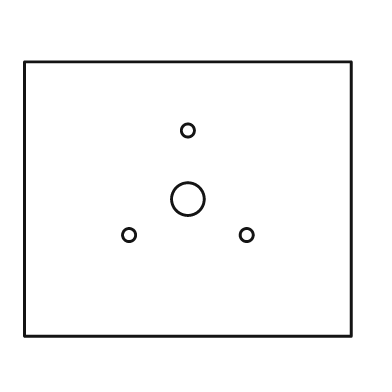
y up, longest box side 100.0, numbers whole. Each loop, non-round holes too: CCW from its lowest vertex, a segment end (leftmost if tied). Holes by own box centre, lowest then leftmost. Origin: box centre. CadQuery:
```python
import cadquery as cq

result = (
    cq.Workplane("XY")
    .moveTo(-50.0, -42.0)
    .lineTo(50.0, -42.0)
    .lineTo(50.0, 42.0)
    .lineTo(-50.0, 42.0)
    .close()
    .moveTo(-18.0, -11.0)
    .circle(2.0)
    .moveTo(18.0, -11.0)
    .circle(2.0)
    .moveTo(0.0, 0.0)
    .circle(5.0)
    .moveTo(0.0, 21.0)
    .circle(2.0)
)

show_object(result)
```